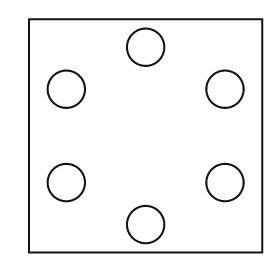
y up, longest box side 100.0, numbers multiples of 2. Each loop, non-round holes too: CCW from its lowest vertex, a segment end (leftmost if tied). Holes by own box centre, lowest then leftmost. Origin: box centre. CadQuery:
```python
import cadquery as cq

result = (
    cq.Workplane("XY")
    .moveTo(-50.0, -50.0)
    .lineTo(50.0, -50.0)
    .lineTo(50.0, 50.0)
    .lineTo(-50.0, 50.0)
    .close()
    .moveTo(0.0, -38.0)
    .circle(8.0)
    .moveTo(-34.0, -20.0)
    .circle(8.0)
    .moveTo(34.0, -20.0)
    .circle(8.0)
    .moveTo(-34.0, 20.0)
    .circle(8.0)
    .moveTo(34.0, 20.0)
    .circle(8.0)
    .moveTo(0.0, 38.0)
    .circle(8.0)
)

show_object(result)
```